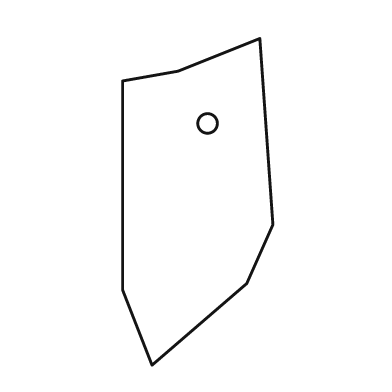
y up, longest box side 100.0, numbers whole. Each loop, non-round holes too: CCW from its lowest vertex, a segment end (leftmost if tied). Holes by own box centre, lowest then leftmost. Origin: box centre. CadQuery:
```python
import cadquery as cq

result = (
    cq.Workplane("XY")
    .moveTo(-14.0, -50.0)
    .lineTo(15.0, -25.0)
    .lineTo(23.0, -7.0)
    .lineTo(19.0, 50.0)
    .lineTo(-6.0, 40.0)
    .lineTo(-23.0, 37.0)
    .lineTo(-23.0, -27.0)
    .close()
    .moveTo(3.0, 24.0)
    .circle(3.0)
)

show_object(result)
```